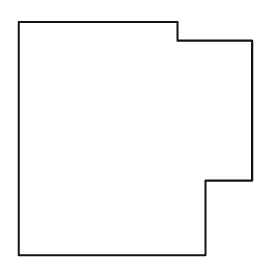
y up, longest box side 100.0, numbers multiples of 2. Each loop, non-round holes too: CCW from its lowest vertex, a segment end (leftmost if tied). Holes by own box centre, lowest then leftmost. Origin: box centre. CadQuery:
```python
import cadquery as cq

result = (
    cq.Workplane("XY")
    .moveTo(-50.0, -50.0)
    .lineTo(30.0, -50.0)
    .lineTo(30.0, -18.0)
    .lineTo(50.0, -18.0)
    .lineTo(50.0, 42.0)
    .lineTo(18.0, 42.0)
    .lineTo(18.0, 50.0)
    .lineTo(-50.0, 50.0)
    .close()
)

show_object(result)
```